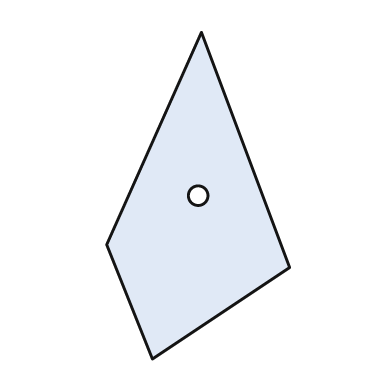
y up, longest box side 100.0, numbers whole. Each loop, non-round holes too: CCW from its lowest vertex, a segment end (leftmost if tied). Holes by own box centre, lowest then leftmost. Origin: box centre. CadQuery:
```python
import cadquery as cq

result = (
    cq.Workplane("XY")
    .moveTo(-14.0, -50.0)
    .lineTo(28.0, -22.0)
    .lineTo(1.0, 50.0)
    .lineTo(-28.0, -15.0)
    .close()
    .moveTo(0.0, 0.0)
    .circle(3.0)
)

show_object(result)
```